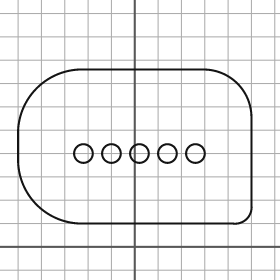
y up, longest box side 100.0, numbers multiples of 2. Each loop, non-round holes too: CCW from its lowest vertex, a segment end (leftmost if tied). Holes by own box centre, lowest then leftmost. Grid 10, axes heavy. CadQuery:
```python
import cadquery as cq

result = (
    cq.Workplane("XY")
    .moveTo(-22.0, 10.0)
    .lineTo(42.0, 10.0)
    .threePointArc((48.0, 12.0), (50.0, 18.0))
    .lineTo(50.0, 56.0)
    .threePointArc((44.0, 70.0), (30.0, 76.0))
    .lineTo(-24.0, 76.0)
    .threePointArc((-42.0, 68.0), (-50.0, 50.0))
    .lineTo(-50.0, 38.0)
    .threePointArc((-42.0, 18.0), (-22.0, 10.0))
    .close()
    .moveTo(-22.0, 40.0)
    .circle(4.0)
    .moveTo(-10.0, 40.0)
    .circle(4.0)
    .moveTo(2.0, 40.0)
    .circle(4.0)
    .moveTo(14.0, 40.0)
    .circle(4.0)
    .moveTo(26.0, 40.0)
    .circle(4.0)
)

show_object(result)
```